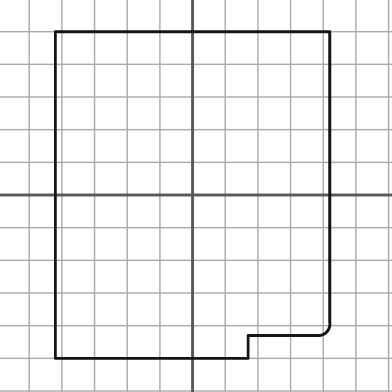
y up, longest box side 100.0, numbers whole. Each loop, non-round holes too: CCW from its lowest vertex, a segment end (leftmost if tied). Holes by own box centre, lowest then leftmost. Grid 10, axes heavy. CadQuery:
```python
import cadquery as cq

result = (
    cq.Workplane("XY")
    .moveTo(-42.0, -50.0)
    .lineTo(17.0, -50.0)
    .lineTo(17.0, -43.0)
    .lineTo(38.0, -43.0)
    .threePointArc((41.0, -42.0), (42.0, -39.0))
    .lineTo(42.0, 50.0)
    .lineTo(-42.0, 50.0)
    .close()
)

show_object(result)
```